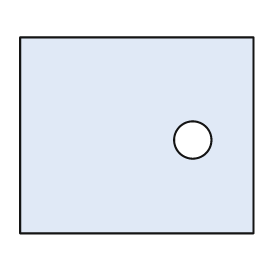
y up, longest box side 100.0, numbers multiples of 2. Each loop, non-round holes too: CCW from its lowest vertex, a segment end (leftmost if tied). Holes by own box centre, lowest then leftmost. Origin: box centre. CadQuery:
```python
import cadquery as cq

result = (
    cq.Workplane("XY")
    .moveTo(-50.0, -42.0)
    .lineTo(50.0, -42.0)
    .lineTo(50.0, 42.0)
    .lineTo(-50.0, 42.0)
    .close()
    .moveTo(24.0, -2.0)
    .circle(8.0)
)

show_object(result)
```